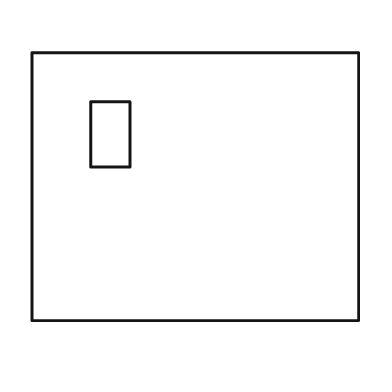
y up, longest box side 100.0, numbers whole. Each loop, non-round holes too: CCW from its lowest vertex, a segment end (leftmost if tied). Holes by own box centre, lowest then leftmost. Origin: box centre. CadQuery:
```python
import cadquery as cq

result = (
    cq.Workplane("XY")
    .moveTo(-50.0, -41.0)
    .lineTo(50.0, -41.0)
    .lineTo(50.0, 41.0)
    .lineTo(-50.0, 41.0)
    .close()
    .moveTo(-32.0, 6.0)
    .lineTo(-20.0, 6.0)
    .lineTo(-20.0, 26.0)
    .lineTo(-32.0, 26.0)
    .close()
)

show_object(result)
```